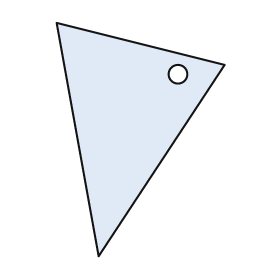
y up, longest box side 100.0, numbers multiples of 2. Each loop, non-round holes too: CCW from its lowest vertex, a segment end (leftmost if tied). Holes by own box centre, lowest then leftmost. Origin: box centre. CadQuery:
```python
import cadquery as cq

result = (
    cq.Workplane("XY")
    .moveTo(-18.0, -50.0)
    .lineTo(36.0, 32.0)
    .lineTo(-36.0, 50.0)
    .close()
    .moveTo(16.0, 28.0)
    .circle(4.0)
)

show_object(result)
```